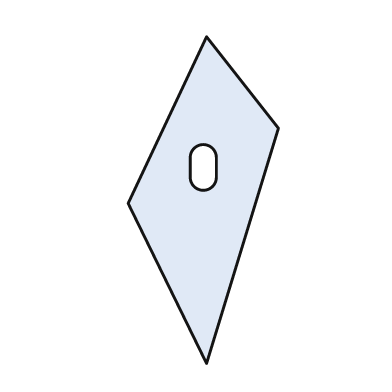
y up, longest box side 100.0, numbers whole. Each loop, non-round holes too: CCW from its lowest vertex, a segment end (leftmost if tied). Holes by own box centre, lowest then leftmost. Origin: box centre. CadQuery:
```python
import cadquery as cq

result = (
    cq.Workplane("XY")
    .moveTo(1.0, -50.0)
    .lineTo(23.0, 22.0)
    .lineTo(1.0, 50.0)
    .lineTo(-23.0, -1.0)
    .close()
    .moveTo(-4.0, 7.0)
    .threePointArc((0.0, 3.0), (4.0, 7.0))
    .lineTo(4.0, 13.0)
    .threePointArc((0.0, 17.0), (-4.0, 13.0))
    .close()
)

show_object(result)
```